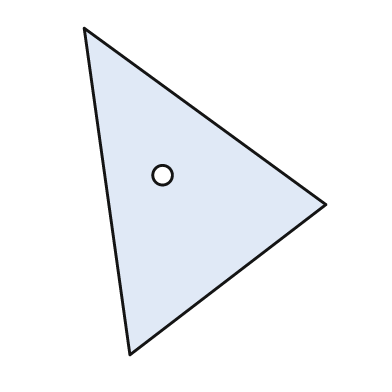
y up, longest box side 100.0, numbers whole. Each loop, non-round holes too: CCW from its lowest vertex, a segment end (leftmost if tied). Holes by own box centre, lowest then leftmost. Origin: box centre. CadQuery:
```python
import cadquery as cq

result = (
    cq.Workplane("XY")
    .moveTo(-23.0, -50.0)
    .lineTo(37.0, -4.0)
    .lineTo(-37.0, 50.0)
    .close()
    .moveTo(-13.0, 5.0)
    .circle(3.0)
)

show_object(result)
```